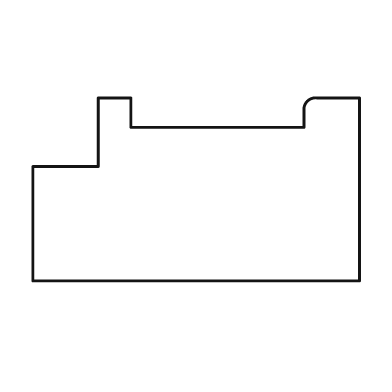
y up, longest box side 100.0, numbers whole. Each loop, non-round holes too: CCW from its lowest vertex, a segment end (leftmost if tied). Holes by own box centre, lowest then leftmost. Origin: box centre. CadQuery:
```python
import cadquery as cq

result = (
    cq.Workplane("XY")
    .moveTo(-50.0, -28.0)
    .lineTo(50.0, -28.0)
    .lineTo(50.0, 28.0)
    .lineTo(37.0, 28.0)
    .threePointArc((34.0, 27.0), (33.0, 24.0))
    .lineTo(33.0, 19.0)
    .lineTo(-20.0, 19.0)
    .lineTo(-20.0, 28.0)
    .lineTo(-30.0, 28.0)
    .lineTo(-30.0, 7.0)
    .lineTo(-50.0, 7.0)
    .close()
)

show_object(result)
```